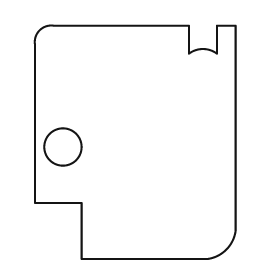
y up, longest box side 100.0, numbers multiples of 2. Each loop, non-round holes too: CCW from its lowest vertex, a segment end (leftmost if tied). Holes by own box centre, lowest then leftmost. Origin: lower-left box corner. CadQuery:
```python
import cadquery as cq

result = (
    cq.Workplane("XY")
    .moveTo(20.0, 0.0)
    .lineTo(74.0, 0.0)
    .threePointArc((82.0, 4.0), (86.0, 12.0))
    .lineTo(86.0, 100.0)
    .lineTo(78.0, 100.0)
    .lineTo(78.0, 88.0)
    .threePointArc((72.0, 90.0), (66.0, 88.0))
    .lineTo(66.0, 100.0)
    .lineTo(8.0, 100.0)
    .threePointArc((2.0, 98.0), (0.0, 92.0))
    .lineTo(0.0, 24.0)
    .lineTo(20.0, 24.0)
    .close()
    .moveTo(12.0, 48.0)
    .circle(8.0)
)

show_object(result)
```